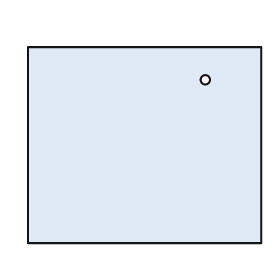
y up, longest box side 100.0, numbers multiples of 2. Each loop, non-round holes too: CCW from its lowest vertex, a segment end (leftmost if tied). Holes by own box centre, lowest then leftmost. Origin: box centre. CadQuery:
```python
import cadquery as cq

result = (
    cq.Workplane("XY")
    .moveTo(-50.0, -42.0)
    .lineTo(50.0, -42.0)
    .lineTo(50.0, 42.0)
    .lineTo(-50.0, 42.0)
    .close()
    .moveTo(26.0, 28.0)
    .circle(2.0)
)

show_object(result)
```